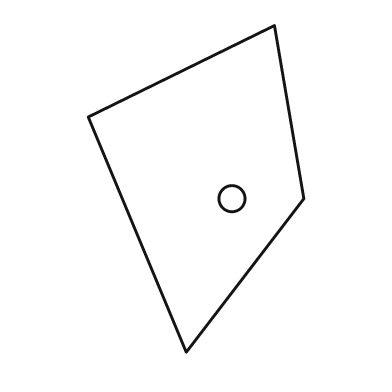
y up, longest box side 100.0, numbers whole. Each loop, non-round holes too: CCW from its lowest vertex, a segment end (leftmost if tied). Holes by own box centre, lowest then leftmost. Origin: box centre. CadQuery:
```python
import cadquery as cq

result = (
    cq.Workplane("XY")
    .moveTo(-3.0, -50.0)
    .lineTo(33.0, -3.0)
    .lineTo(24.0, 50.0)
    .lineTo(-33.0, 22.0)
    .close()
    .moveTo(11.0, -3.0)
    .circle(4.0)
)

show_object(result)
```